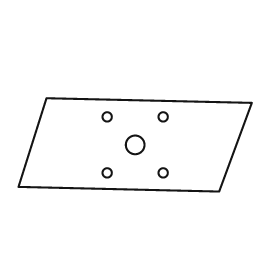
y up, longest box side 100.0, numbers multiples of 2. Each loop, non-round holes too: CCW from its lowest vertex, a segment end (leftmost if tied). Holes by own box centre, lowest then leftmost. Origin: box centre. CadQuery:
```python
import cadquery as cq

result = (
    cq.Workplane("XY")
    .moveTo(36.0, -20.0)
    .lineTo(50.0, 18.0)
    .lineTo(-38.0, 20.0)
    .lineTo(-50.0, -18.0)
    .close()
    .moveTo(-12.0, -12.0)
    .circle(2.0)
    .moveTo(12.0, -12.0)
    .circle(2.0)
    .moveTo(0.0, 0.0)
    .circle(4.0)
    .moveTo(-12.0, 12.0)
    .circle(2.0)
    .moveTo(12.0, 12.0)
    .circle(2.0)
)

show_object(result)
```